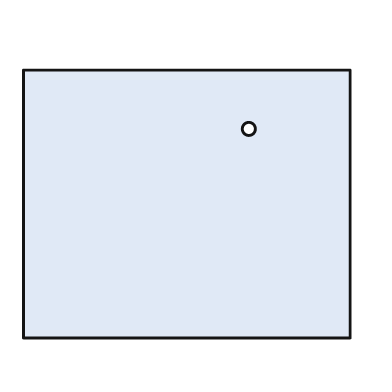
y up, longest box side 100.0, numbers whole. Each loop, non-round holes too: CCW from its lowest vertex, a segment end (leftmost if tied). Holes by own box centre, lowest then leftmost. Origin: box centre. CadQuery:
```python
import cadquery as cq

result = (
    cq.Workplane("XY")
    .moveTo(-50.0, -41.0)
    .lineTo(50.0, -41.0)
    .lineTo(50.0, 41.0)
    .lineTo(-50.0, 41.0)
    .close()
    .moveTo(19.0, 23.0)
    .circle(2.0)
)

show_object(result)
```